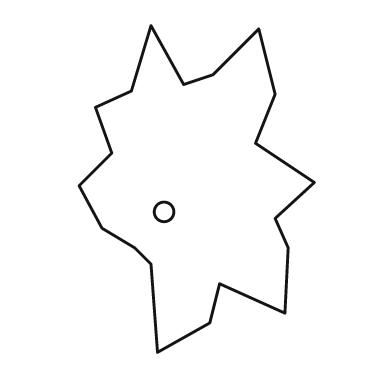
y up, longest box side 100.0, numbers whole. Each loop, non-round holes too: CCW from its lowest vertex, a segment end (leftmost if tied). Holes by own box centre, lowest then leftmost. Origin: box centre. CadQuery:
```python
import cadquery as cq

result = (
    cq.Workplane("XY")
    .moveTo(-12.0, -50.0)
    .lineTo(4.0, -41.0)
    .lineTo(7.0, -29.0)
    .lineTo(27.0, -38.0)
    .lineTo(28.0, -18.0)
    .lineTo(24.0, -9.0)
    .lineTo(36.0, 2.0)
    .lineTo(18.0, 14.0)
    .lineTo(24.0, 29.0)
    .lineTo(19.0, 49.0)
    .lineTo(5.0, 35.0)
    .lineTo(-4.0, 32.0)
    .lineTo(-14.0, 50.0)
    .lineTo(-20.0, 30.0)
    .lineTo(-31.0, 25.0)
    .lineTo(-26.0, 11.0)
    .lineTo(-36.0, 1.0)
    .lineTo(-29.0, -12.0)
    .lineTo(-19.0, -18.0)
    .lineTo(-14.0, -23.0)
    .close()
    .moveTo(-10.0, -7.0)
    .circle(3.0)
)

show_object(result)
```